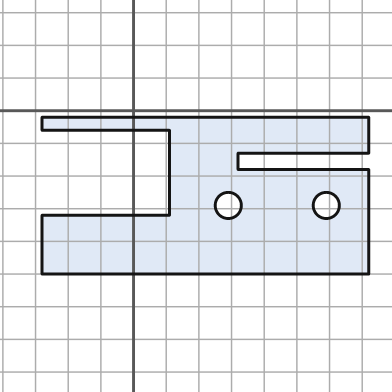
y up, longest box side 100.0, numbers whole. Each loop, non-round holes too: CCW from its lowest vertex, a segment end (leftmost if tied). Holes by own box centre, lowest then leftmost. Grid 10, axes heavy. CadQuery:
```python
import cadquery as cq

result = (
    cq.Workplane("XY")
    .moveTo(-28.0, -50.0)
    .lineTo(72.0, -50.0)
    .lineTo(72.0, -18.0)
    .lineTo(32.0, -18.0)
    .lineTo(32.0, -13.0)
    .lineTo(72.0, -13.0)
    .lineTo(72.0, -2.0)
    .lineTo(-28.0, -2.0)
    .lineTo(-28.0, -6.0)
    .lineTo(11.0, -6.0)
    .lineTo(11.0, -32.0)
    .lineTo(-28.0, -32.0)
    .close()
    .moveTo(29.0, -29.0)
    .circle(4.0)
    .moveTo(59.0, -29.0)
    .circle(4.0)
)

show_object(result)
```